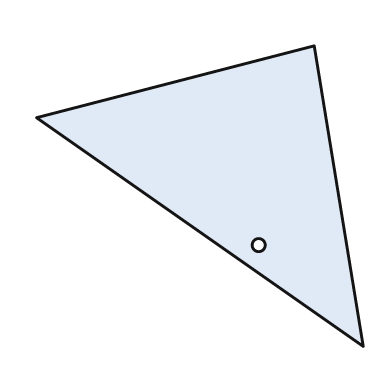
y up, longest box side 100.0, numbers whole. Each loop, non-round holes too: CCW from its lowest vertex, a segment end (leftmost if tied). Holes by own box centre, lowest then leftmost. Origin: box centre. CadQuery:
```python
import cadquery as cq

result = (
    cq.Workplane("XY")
    .moveTo(50.0, -46.0)
    .lineTo(35.0, 46.0)
    .lineTo(-50.0, 24.0)
    .close()
    .moveTo(18.0, -15.0)
    .circle(2.0)
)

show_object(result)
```